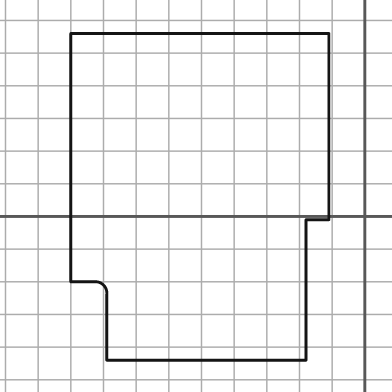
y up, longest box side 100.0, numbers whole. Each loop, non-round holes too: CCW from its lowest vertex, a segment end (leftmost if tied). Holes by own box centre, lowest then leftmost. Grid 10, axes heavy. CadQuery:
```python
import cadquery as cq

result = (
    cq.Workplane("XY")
    .moveTo(-79.0, -44.0)
    .lineTo(-18.0, -44.0)
    .lineTo(-18.0, -1.0)
    .lineTo(-11.0, -1.0)
    .lineTo(-11.0, 56.0)
    .lineTo(-90.0, 56.0)
    .lineTo(-90.0, -20.0)
    .lineTo(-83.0, -20.0)
    .threePointArc((-80.0, -21.0), (-79.0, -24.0))
    .close()
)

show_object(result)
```